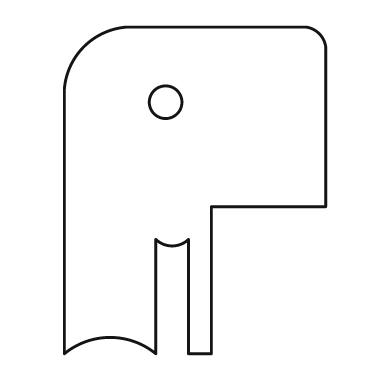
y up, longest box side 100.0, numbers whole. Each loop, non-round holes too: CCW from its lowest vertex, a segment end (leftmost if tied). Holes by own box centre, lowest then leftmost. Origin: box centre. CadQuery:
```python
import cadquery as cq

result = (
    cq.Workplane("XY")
    .moveTo(-40.0, -50.0)
    .threePointArc((-26.0, -45.0), (-12.0, -50.0))
    .lineTo(-12.0, -15.0)
    .threePointArc((-7.0, -17.0), (-2.0, -15.0))
    .lineTo(-2.0, -50.0)
    .lineTo(5.0, -50.0)
    .lineTo(5.0, -5.0)
    .lineTo(40.0, -5.0)
    .lineTo(40.0, 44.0)
    .threePointArc((38.0, 48.0), (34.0, 50.0))
    .lineTo(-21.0, 50.0)
    .threePointArc((-34.0, 44.0), (-40.0, 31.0))
    .close()
    .moveTo(-9.0, 27.0)
    .circle(5.0)
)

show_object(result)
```